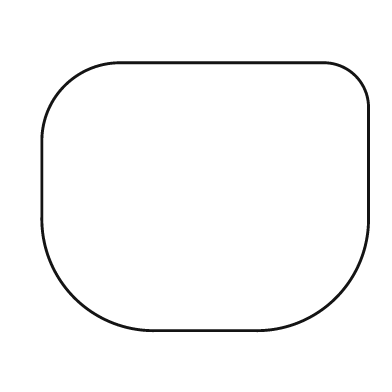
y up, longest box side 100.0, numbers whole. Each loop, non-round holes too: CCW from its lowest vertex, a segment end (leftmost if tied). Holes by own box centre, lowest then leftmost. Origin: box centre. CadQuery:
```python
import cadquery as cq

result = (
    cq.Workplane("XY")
    .moveTo(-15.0, -41.0)
    .lineTo(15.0, -41.0)
    .threePointArc((40.0, -31.0), (50.0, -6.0))
    .lineTo(50.0, 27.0)
    .threePointArc((46.0, 37.0), (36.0, 41.0))
    .lineTo(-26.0, 41.0)
    .threePointArc((-43.0, 34.0), (-50.0, 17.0))
    .lineTo(-50.0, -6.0)
    .threePointArc((-40.0, -31.0), (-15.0, -41.0))
    .close()
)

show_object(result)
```